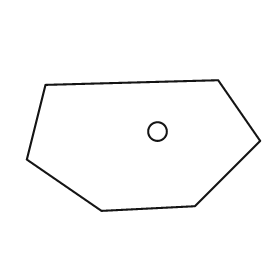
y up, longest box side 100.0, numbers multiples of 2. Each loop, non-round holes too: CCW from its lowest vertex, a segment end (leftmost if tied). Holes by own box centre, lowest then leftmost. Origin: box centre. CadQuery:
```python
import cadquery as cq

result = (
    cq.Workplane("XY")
    .moveTo(-18.0, -28.0)
    .lineTo(22.0, -26.0)
    .lineTo(50.0, 2.0)
    .lineTo(32.0, 28.0)
    .lineTo(-42.0, 26.0)
    .lineTo(-50.0, -6.0)
    .close()
    .moveTo(6.0, 6.0)
    .circle(4.0)
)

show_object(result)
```